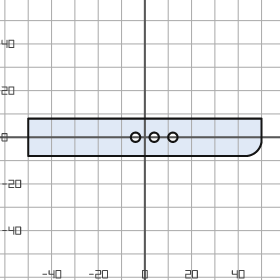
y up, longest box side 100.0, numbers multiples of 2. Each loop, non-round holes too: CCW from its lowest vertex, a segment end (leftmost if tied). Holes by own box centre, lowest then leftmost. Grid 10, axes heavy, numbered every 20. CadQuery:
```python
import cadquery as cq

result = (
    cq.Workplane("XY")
    .moveTo(-50.0, -8.0)
    .lineTo(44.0, -8.0)
    .threePointArc((48.0, -6.0), (50.0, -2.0))
    .lineTo(50.0, 8.0)
    .lineTo(-50.0, 8.0)
    .close()
    .moveTo(-4.0, 0.0)
    .circle(2.0)
    .moveTo(4.0, 0.0)
    .circle(2.0)
    .moveTo(12.0, 0.0)
    .circle(2.0)
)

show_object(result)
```